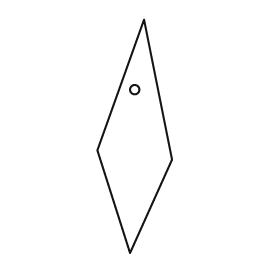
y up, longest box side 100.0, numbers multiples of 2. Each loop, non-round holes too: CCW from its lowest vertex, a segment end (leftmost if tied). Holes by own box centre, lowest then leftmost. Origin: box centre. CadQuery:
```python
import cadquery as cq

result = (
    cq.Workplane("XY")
    .moveTo(-2.0, -50.0)
    .lineTo(16.0, -10.0)
    .lineTo(4.0, 50.0)
    .lineTo(-16.0, -6.0)
    .close()
    .moveTo(0.0, 20.0)
    .circle(2.0)
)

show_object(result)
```